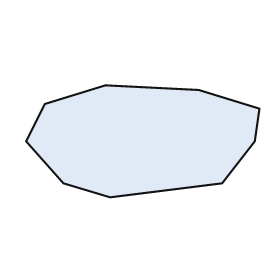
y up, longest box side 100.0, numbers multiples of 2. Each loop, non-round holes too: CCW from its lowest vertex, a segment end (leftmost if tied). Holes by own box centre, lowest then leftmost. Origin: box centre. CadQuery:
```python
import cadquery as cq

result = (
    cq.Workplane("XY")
    .moveTo(-14.0, -24.0)
    .lineTo(34.0, -18.0)
    .lineTo(48.0, 0.0)
    .lineTo(50.0, 14.0)
    .lineTo(24.0, 22.0)
    .lineTo(-16.0, 24.0)
    .lineTo(-42.0, 16.0)
    .lineTo(-50.0, 0.0)
    .lineTo(-34.0, -18.0)
    .close()
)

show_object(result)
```